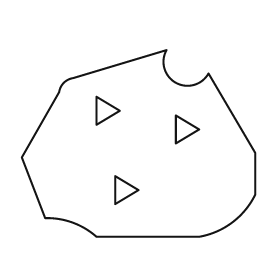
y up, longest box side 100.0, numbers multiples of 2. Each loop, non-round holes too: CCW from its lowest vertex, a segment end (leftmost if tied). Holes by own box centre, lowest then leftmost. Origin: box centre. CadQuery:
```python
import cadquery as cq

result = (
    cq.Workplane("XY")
    .moveTo(-18.0, -40.0)
    .lineTo(26.0, -40.0)
    .threePointArc((40.0, -34.0), (50.0, -22.0))
    .lineTo(50.0, -4.0)
    .lineTo(30.0, 30.0)
    .threePointArc((16.0, 26.0), (12.0, 40.0))
    .lineTo(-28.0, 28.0)
    .threePointArc((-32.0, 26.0), (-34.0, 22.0))
    .lineTo(-50.0, -6.0)
    .lineTo(-40.0, -32.0)
    .threePointArc((-28.0, -34.0), (-18.0, -40.0))
    .close()
    .moveTo(-10.0, -26.0)
    .lineTo(0.0, -20.0)
    .lineTo(-10.0, -14.0)
    .close()
    .moveTo(16.0, 0.0)
    .lineTo(26.0, 6.0)
    .lineTo(16.0, 12.0)
    .close()
    .moveTo(-18.0, 8.0)
    .lineTo(-8.0, 14.0)
    .lineTo(-18.0, 20.0)
    .close()
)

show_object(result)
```